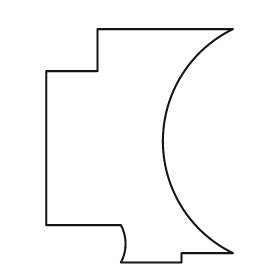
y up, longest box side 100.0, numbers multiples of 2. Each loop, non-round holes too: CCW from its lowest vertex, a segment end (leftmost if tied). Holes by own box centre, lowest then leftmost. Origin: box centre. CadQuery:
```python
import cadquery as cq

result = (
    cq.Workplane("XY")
    .moveTo(-8.0, -50.0)
    .lineTo(18.0, -50.0)
    .lineTo(18.0, -46.0)
    .lineTo(40.0, -46.0)
    .threePointArc((10.0, 2.0), (40.0, 50.0))
    .lineTo(-18.0, 50.0)
    .lineTo(-18.0, 32.0)
    .lineTo(-40.0, 32.0)
    .lineTo(-40.0, -34.0)
    .lineTo(-8.0, -34.0)
    .threePointArc((-6.0, -42.0), (-8.0, -50.0))
    .close()
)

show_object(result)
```